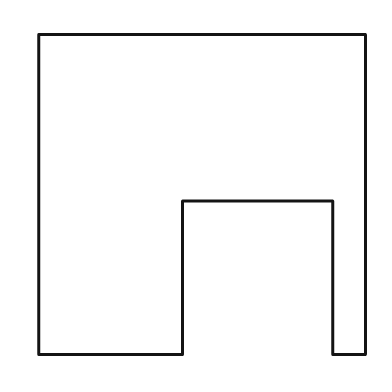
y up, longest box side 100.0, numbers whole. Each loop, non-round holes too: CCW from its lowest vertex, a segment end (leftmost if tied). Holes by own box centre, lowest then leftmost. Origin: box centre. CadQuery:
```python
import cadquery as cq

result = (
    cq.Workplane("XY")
    .moveTo(-50.0, -49.0)
    .lineTo(-6.0, -49.0)
    .lineTo(-6.0, -2.0)
    .lineTo(40.0, -2.0)
    .lineTo(40.0, -49.0)
    .lineTo(50.0, -49.0)
    .lineTo(50.0, 49.0)
    .lineTo(-50.0, 49.0)
    .close()
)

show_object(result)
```